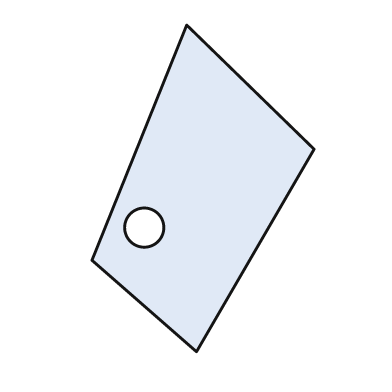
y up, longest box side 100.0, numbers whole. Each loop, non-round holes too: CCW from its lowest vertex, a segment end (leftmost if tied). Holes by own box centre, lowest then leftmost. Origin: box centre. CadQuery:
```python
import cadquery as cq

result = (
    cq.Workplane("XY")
    .moveTo(-2.0, -50.0)
    .lineTo(34.0, 12.0)
    .lineTo(-5.0, 50.0)
    .lineTo(-34.0, -22.0)
    .close()
    .moveTo(-18.0, -12.0)
    .circle(6.0)
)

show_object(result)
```